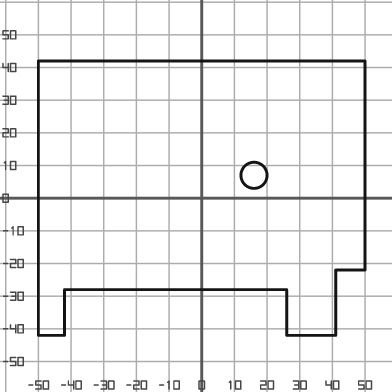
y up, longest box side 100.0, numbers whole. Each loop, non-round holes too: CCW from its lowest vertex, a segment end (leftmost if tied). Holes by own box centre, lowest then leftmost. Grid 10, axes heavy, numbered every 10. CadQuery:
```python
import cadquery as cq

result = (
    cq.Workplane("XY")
    .moveTo(-50.0, -42.0)
    .lineTo(-42.0, -42.0)
    .lineTo(-42.0, -28.0)
    .lineTo(26.0, -28.0)
    .lineTo(26.0, -42.0)
    .lineTo(41.0, -42.0)
    .lineTo(41.0, -22.0)
    .lineTo(50.0, -22.0)
    .lineTo(50.0, 42.0)
    .lineTo(-50.0, 42.0)
    .close()
    .moveTo(16.0, 7.0)
    .circle(4.0)
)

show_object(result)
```